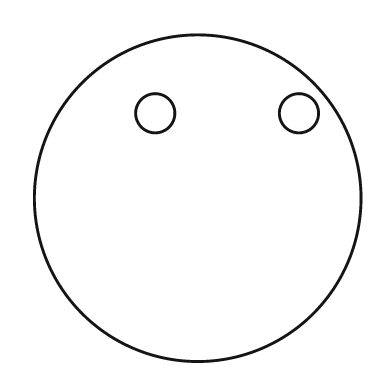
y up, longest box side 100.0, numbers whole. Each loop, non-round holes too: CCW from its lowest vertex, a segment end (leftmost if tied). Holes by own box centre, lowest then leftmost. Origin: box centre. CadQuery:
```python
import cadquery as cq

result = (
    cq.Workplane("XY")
    .moveTo(0.0, 0.0)
    .circle(50.0)
    .moveTo(-13.0, 26.0)
    .circle(6.0)
    .moveTo(31.0, 26.0)
    .circle(6.0)
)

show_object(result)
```